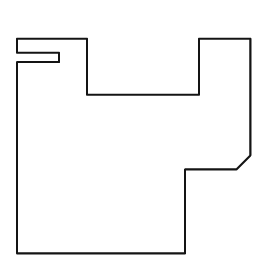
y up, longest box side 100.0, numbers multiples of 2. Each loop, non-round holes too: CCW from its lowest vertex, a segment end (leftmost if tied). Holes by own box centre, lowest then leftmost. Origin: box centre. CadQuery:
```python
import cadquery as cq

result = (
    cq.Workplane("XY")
    .moveTo(-50.0, -46.0)
    .lineTo(22.0, -46.0)
    .lineTo(22.0, -10.0)
    .lineTo(44.0, -10.0)
    .lineTo(50.0, -4.0)
    .lineTo(50.0, 46.0)
    .lineTo(28.0, 46.0)
    .lineTo(28.0, 22.0)
    .lineTo(-20.0, 22.0)
    .lineTo(-20.0, 46.0)
    .lineTo(-50.0, 46.0)
    .lineTo(-50.0, 40.0)
    .lineTo(-32.0, 40.0)
    .lineTo(-32.0, 36.0)
    .lineTo(-50.0, 36.0)
    .close()
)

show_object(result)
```